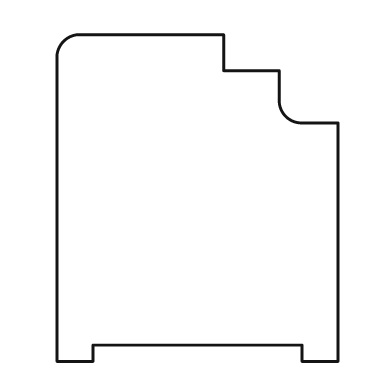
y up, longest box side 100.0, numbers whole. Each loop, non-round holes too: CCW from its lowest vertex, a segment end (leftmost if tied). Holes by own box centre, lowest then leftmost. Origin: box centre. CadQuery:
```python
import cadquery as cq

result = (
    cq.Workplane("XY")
    .moveTo(-43.0, -50.0)
    .lineTo(-32.0, -50.0)
    .lineTo(-32.0, -45.0)
    .lineTo(32.0, -45.0)
    .lineTo(32.0, -50.0)
    .lineTo(43.0, -50.0)
    .lineTo(43.0, 23.0)
    .lineTo(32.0, 23.0)
    .threePointArc((27.0, 25.0), (25.0, 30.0))
    .lineTo(25.0, 39.0)
    .lineTo(8.0, 39.0)
    .lineTo(8.0, 50.0)
    .lineTo(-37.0, 50.0)
    .threePointArc((-41.0, 48.0), (-43.0, 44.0))
    .close()
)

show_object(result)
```